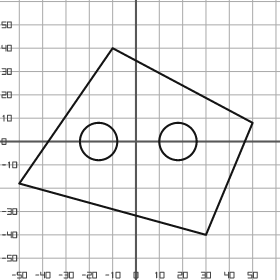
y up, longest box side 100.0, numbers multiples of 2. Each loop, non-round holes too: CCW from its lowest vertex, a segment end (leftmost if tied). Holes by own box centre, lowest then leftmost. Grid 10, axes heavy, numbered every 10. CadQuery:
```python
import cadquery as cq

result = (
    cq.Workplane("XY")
    .moveTo(30.0, -40.0)
    .lineTo(50.0, 8.0)
    .lineTo(-10.0, 40.0)
    .lineTo(-50.0, -18.0)
    .close()
    .moveTo(-16.0, 0.0)
    .circle(8.0)
    .moveTo(18.0, 0.0)
    .circle(8.0)
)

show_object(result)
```